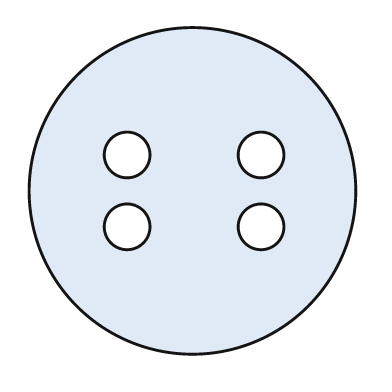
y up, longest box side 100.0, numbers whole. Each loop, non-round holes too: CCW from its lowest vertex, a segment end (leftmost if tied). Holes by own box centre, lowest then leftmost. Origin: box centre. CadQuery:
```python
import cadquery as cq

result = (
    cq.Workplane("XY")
    .moveTo(0.0, 0.0)
    .circle(50.0)
    .moveTo(-20.0, -11.0)
    .circle(7.0)
    .moveTo(21.0, -11.0)
    .circle(7.0)
    .moveTo(-20.0, 11.0)
    .circle(7.0)
    .moveTo(21.0, 11.0)
    .circle(7.0)
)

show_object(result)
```